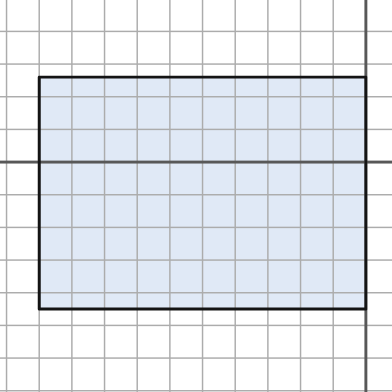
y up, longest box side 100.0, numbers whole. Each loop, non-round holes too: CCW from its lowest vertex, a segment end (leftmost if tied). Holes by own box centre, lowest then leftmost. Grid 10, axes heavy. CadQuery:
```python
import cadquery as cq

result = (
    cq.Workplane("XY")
    .moveTo(-100.0, -45.0)
    .lineTo(0.0, -45.0)
    .lineTo(0.0, 26.0)
    .lineTo(-100.0, 26.0)
    .close()
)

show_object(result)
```